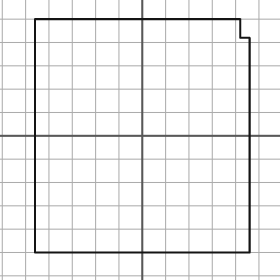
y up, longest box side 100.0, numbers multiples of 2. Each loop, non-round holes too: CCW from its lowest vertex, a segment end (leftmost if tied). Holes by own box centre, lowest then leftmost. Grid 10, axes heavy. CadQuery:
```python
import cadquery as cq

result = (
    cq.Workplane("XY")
    .moveTo(-46.0, -50.0)
    .lineTo(46.0, -50.0)
    .lineTo(46.0, 42.0)
    .lineTo(42.0, 42.0)
    .lineTo(42.0, 50.0)
    .lineTo(-46.0, 50.0)
    .close()
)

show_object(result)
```